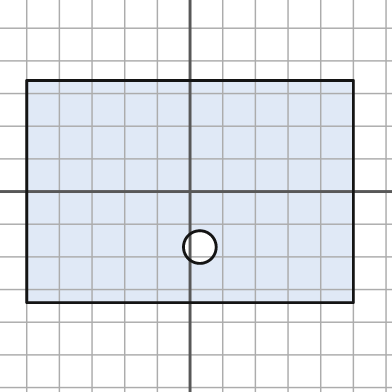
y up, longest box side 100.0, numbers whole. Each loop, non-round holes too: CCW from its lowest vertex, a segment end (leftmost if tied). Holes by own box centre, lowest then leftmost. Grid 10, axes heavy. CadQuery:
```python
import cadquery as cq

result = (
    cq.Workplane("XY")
    .moveTo(-50.0, -34.0)
    .lineTo(50.0, -34.0)
    .lineTo(50.0, 34.0)
    .lineTo(-50.0, 34.0)
    .close()
    .moveTo(3.0, -17.0)
    .circle(5.0)
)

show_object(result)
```